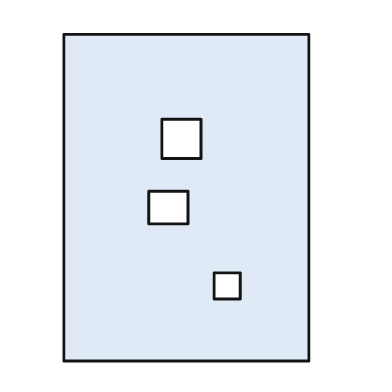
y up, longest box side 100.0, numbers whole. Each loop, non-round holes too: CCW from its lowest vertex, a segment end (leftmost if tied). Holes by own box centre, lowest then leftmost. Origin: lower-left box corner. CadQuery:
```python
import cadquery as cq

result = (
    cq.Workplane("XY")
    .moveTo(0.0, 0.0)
    .lineTo(75.0, 0.0)
    .lineTo(75.0, 100.0)
    .lineTo(0.0, 100.0)
    .close()
    .moveTo(46.0, 19.0)
    .lineTo(54.0, 19.0)
    .lineTo(54.0, 27.0)
    .lineTo(46.0, 27.0)
    .close()
    .moveTo(26.0, 42.0)
    .lineTo(38.0, 42.0)
    .lineTo(38.0, 52.0)
    .lineTo(26.0, 52.0)
    .close()
    .moveTo(30.0, 62.0)
    .lineTo(42.0, 62.0)
    .lineTo(42.0, 74.0)
    .lineTo(30.0, 74.0)
    .close()
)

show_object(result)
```